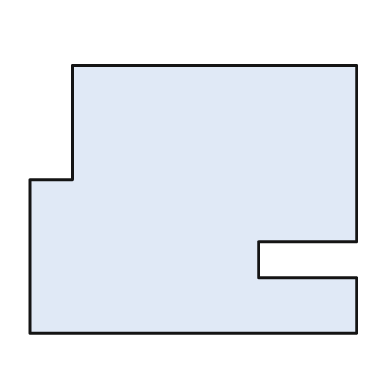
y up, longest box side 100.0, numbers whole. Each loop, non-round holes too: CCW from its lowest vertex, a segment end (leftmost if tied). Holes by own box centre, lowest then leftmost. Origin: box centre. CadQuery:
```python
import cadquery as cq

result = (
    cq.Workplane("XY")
    .moveTo(-50.0, -41.0)
    .lineTo(50.0, -41.0)
    .lineTo(50.0, -24.0)
    .lineTo(20.0, -24.0)
    .lineTo(20.0, -13.0)
    .lineTo(50.0, -13.0)
    .lineTo(50.0, 41.0)
    .lineTo(-37.0, 41.0)
    .lineTo(-37.0, 6.0)
    .lineTo(-50.0, 6.0)
    .close()
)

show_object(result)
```